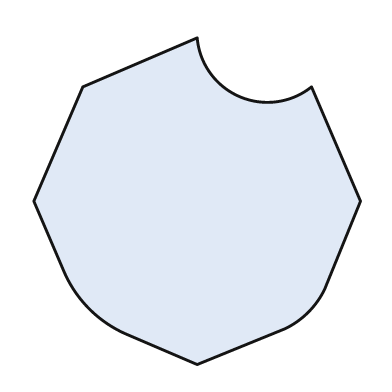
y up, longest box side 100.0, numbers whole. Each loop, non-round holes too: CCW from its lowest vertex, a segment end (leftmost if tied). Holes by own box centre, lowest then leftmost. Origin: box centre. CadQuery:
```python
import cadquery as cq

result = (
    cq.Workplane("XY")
    .moveTo(0.0, -50.0)
    .lineTo(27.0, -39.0)
    .threePointArc((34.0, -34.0), (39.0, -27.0))
    .lineTo(50.0, 0.0)
    .lineTo(35.0, 35.0)
    .threePointArc((13.0, 32.0), (0.0, 50.0))
    .lineTo(-35.0, 35.0)
    .lineTo(-50.0, 0.0)
    .lineTo(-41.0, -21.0)
    .threePointArc((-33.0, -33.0), (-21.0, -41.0))
    .close()
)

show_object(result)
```